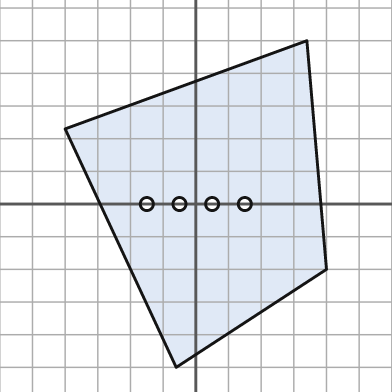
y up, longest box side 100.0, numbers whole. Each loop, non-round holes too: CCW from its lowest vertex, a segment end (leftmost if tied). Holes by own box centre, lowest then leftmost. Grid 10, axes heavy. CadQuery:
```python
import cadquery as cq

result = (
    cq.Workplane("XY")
    .moveTo(-6.0, -50.0)
    .lineTo(40.0, -20.0)
    .lineTo(34.0, 50.0)
    .lineTo(-40.0, 23.0)
    .close()
    .moveTo(-15.0, 0.0)
    .circle(2.0)
    .moveTo(-5.0, 0.0)
    .circle(2.0)
    .moveTo(5.0, 0.0)
    .circle(2.0)
    .moveTo(15.0, 0.0)
    .circle(2.0)
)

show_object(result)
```